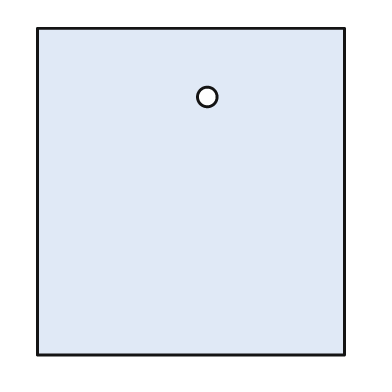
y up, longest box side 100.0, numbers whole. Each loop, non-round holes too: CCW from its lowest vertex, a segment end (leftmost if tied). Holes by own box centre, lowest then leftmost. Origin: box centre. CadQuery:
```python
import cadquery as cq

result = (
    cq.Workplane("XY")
    .moveTo(-47.0, -50.0)
    .lineTo(47.0, -50.0)
    .lineTo(47.0, 50.0)
    .lineTo(-47.0, 50.0)
    .close()
    .moveTo(5.0, 29.0)
    .circle(3.0)
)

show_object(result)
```